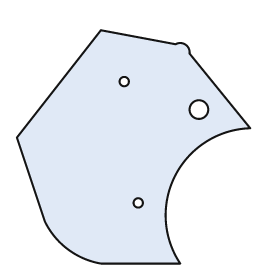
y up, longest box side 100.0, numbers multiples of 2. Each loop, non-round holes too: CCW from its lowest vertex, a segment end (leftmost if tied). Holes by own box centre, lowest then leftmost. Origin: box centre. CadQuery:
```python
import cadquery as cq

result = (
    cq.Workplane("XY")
    .moveTo(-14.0, -50.0)
    .lineTo(20.0, -50.0)
    .threePointArc((18.0, -12.0), (50.0, 8.0))
    .lineTo(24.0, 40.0)
    .threePointArc((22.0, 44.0), (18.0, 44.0))
    .lineTo(-14.0, 50.0)
    .lineTo(-50.0, 4.0)
    .lineTo(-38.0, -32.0)
    .threePointArc((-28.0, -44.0), (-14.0, -50.0))
    .close()
    .moveTo(2.0, -24.0)
    .circle(2.0)
    .moveTo(28.0, 16.0)
    .circle(4.0)
    .moveTo(-4.0, 28.0)
    .circle(2.0)
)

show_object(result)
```